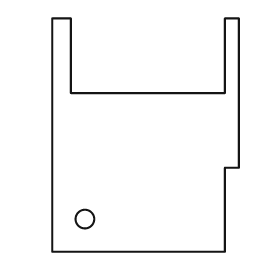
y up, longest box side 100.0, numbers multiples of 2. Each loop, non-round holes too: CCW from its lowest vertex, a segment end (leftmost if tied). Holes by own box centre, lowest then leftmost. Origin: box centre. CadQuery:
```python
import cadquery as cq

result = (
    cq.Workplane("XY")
    .moveTo(-40.0, -50.0)
    .lineTo(34.0, -50.0)
    .lineTo(34.0, -14.0)
    .lineTo(40.0, -14.0)
    .lineTo(40.0, 50.0)
    .lineTo(34.0, 50.0)
    .lineTo(34.0, 18.0)
    .lineTo(-32.0, 18.0)
    .lineTo(-32.0, 50.0)
    .lineTo(-40.0, 50.0)
    .close()
    .moveTo(-26.0, -36.0)
    .circle(4.0)
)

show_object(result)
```